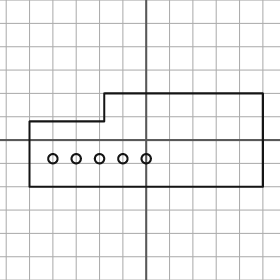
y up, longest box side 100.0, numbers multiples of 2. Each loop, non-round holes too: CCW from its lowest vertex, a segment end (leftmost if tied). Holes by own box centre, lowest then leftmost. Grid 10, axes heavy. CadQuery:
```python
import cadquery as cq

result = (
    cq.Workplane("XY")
    .moveTo(-50.0, -20.0)
    .lineTo(50.0, -20.0)
    .lineTo(50.0, 20.0)
    .lineTo(-18.0, 20.0)
    .lineTo(-18.0, 8.0)
    .lineTo(-50.0, 8.0)
    .close()
    .moveTo(-40.0, -8.0)
    .circle(2.0)
    .moveTo(-30.0, -8.0)
    .circle(2.0)
    .moveTo(-20.0, -8.0)
    .circle(2.0)
    .moveTo(-10.0, -8.0)
    .circle(2.0)
    .moveTo(0.0, -8.0)
    .circle(2.0)
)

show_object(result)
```